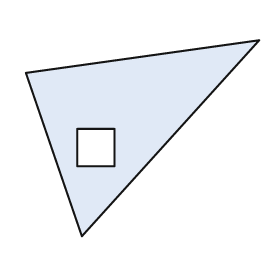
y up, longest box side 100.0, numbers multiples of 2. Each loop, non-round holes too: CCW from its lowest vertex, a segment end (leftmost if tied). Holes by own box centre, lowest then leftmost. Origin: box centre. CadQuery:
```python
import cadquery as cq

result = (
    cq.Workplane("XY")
    .moveTo(-26.0, -42.0)
    .lineTo(50.0, 42.0)
    .lineTo(-50.0, 28.0)
    .close()
    .moveTo(-28.0, -12.0)
    .lineTo(-12.0, -12.0)
    .lineTo(-12.0, 4.0)
    .lineTo(-28.0, 4.0)
    .close()
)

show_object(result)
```